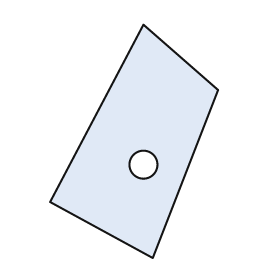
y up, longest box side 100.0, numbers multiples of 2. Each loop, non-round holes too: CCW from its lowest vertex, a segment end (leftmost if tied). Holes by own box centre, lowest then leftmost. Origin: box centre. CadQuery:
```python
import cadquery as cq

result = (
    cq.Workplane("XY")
    .moveTo(8.0, -50.0)
    .lineTo(36.0, 22.0)
    .lineTo(4.0, 50.0)
    .lineTo(-36.0, -26.0)
    .close()
    .moveTo(4.0, -10.0)
    .circle(6.0)
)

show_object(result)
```